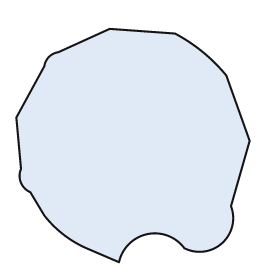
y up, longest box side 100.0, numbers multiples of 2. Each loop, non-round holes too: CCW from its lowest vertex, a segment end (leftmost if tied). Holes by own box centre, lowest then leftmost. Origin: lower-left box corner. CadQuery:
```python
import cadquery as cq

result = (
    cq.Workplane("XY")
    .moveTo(44.0, 0.0)
    .threePointArc((56.0, 12.0), (72.0, 6.0))
    .threePointArc((88.0, 8.0), (92.0, 24.0))
    .lineTo(100.0, 52.0)
    .lineTo(90.0, 80.0)
    .threePointArc((80.0, 90.0), (68.0, 98.0))
    .lineTo(40.0, 100.0)
    .lineTo(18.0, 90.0)
    .threePointArc((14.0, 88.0), (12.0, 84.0))
    .lineTo(0.0, 62.0)
    .lineTo(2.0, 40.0)
    .threePointArc((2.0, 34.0), (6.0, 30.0))
    .lineTo(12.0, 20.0)
    .threePointArc((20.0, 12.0), (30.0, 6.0))
    .close()
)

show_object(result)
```